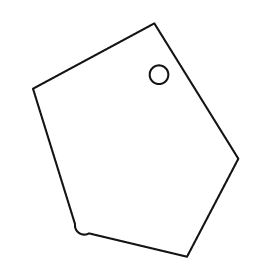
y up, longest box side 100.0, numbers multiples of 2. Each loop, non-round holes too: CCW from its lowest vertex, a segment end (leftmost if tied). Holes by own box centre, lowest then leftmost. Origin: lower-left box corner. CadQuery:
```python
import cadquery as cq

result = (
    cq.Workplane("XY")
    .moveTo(66.0, 0.0)
    .lineTo(88.0, 42.0)
    .lineTo(52.0, 100.0)
    .lineTo(0.0, 72.0)
    .lineTo(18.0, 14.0)
    .threePointArc((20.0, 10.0), (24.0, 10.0))
    .close()
    .moveTo(54.0, 78.0)
    .circle(4.0)
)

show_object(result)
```